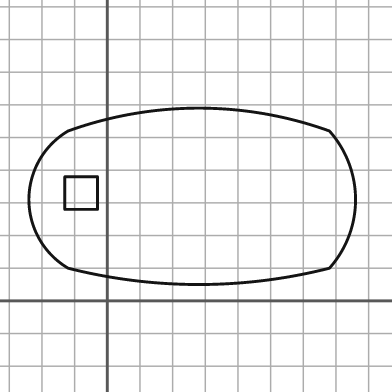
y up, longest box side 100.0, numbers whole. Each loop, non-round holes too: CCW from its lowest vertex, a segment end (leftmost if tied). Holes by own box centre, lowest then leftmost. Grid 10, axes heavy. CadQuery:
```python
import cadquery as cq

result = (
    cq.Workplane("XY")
    .moveTo(-12.0, 10.0)
    .threePointArc((28.0, 5.0), (68.0, 10.0))
    .threePointArc((76.0, 31.0), (68.0, 52.0))
    .threePointArc((28.0, 59.0), (-12.0, 52.0))
    .threePointArc((-24.0, 31.0), (-12.0, 10.0))
    .close()
    .moveTo(-13.0, 28.0)
    .lineTo(-3.0, 28.0)
    .lineTo(-3.0, 38.0)
    .lineTo(-13.0, 38.0)
    .close()
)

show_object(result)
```